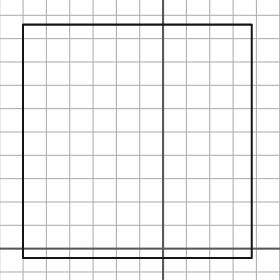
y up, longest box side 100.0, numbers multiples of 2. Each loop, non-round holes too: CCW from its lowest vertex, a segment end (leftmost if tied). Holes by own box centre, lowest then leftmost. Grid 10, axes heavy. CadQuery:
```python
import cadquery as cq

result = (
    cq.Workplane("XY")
    .moveTo(-60.0, -4.0)
    .lineTo(38.0, -4.0)
    .lineTo(38.0, 96.0)
    .lineTo(-60.0, 96.0)
    .close()
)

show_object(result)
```